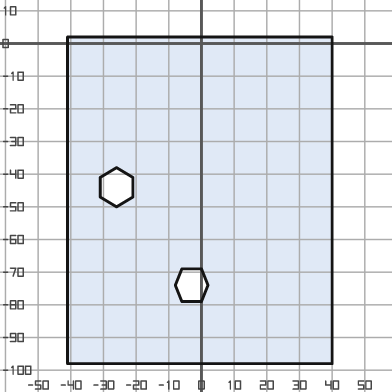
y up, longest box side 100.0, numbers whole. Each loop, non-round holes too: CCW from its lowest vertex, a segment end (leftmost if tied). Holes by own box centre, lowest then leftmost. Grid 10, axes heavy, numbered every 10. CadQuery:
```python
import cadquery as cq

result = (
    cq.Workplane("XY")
    .moveTo(-41.0, -98.0)
    .lineTo(40.0, -98.0)
    .lineTo(40.0, 2.0)
    .lineTo(-41.0, 2.0)
    .close()
    .moveTo(-6.0, -79.0)
    .lineTo(0.0, -79.0)
    .lineTo(2.0, -74.0)
    .lineTo(0.0, -69.0)
    .lineTo(-6.0, -69.0)
    .lineTo(-8.0, -74.0)
    .close()
    .moveTo(-26.0, -50.0)
    .lineTo(-21.0, -47.0)
    .lineTo(-21.0, -41.0)
    .lineTo(-26.0, -38.0)
    .lineTo(-31.0, -41.0)
    .lineTo(-31.0, -47.0)
    .close()
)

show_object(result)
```